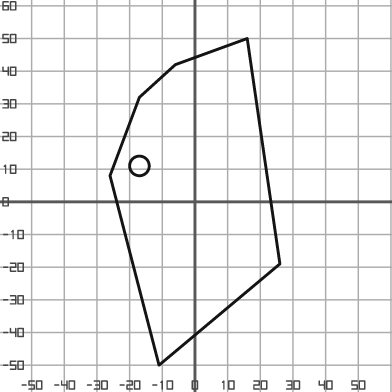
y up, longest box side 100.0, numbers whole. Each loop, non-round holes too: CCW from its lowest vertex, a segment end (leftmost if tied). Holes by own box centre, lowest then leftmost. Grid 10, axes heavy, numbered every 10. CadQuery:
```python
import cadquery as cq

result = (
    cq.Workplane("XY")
    .moveTo(-11.0, -50.0)
    .lineTo(26.0, -19.0)
    .lineTo(16.0, 50.0)
    .lineTo(-6.0, 42.0)
    .lineTo(-17.0, 32.0)
    .lineTo(-26.0, 8.0)
    .close()
    .moveTo(-17.0, 11.0)
    .circle(3.0)
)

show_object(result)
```